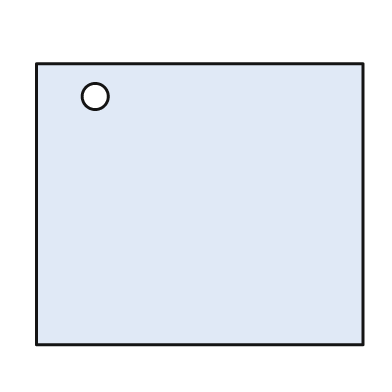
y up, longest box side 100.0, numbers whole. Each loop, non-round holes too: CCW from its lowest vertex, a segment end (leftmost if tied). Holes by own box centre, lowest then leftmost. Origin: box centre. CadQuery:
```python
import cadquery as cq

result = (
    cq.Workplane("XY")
    .moveTo(-50.0, -43.0)
    .lineTo(50.0, -43.0)
    .lineTo(50.0, 43.0)
    .lineTo(-50.0, 43.0)
    .close()
    .moveTo(-32.0, 33.0)
    .circle(4.0)
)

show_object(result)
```